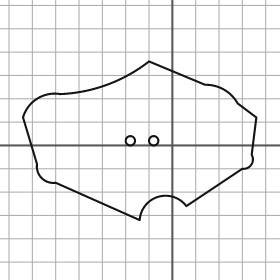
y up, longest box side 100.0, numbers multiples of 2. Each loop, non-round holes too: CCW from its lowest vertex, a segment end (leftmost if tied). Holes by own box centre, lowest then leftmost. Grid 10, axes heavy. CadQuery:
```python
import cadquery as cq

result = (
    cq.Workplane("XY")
    .moveTo(-14.0, -32.0)
    .threePointArc((-6.0, -22.0), (6.0, -26.0))
    .lineTo(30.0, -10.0)
    .threePointArc((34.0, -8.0), (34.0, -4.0))
    .lineTo(36.0, 12.0)
    .lineTo(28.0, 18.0)
    .threePointArc((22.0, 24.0), (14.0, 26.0))
    .lineTo(-10.0, 36.0)
    .threePointArc((-28.0, 26.0), (-48.0, 22.0))
    .threePointArc((-58.0, 20.0), (-64.0, 12.0))
    .lineTo(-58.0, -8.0)
    .threePointArc((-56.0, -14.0), (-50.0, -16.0))
    .close()
    .moveTo(-18.0, 2.0)
    .circle(2.0)
    .moveTo(-8.0, 2.0)
    .circle(2.0)
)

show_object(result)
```